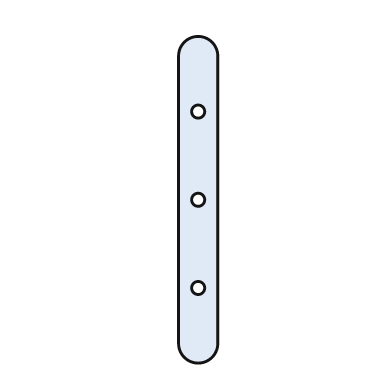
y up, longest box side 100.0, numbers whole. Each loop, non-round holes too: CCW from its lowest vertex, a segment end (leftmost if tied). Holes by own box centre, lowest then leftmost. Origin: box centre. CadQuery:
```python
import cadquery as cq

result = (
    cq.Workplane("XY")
    .moveTo(-6.0, -44.0)
    .threePointArc((0.0, -50.0), (6.0, -44.0))
    .lineTo(6.0, 44.0)
    .threePointArc((0.0, 50.0), (-6.0, 44.0))
    .close()
    .moveTo(0.0, -27.0)
    .circle(2.0)
    .moveTo(0.0, 0.0)
    .circle(2.0)
    .moveTo(0.0, 27.0)
    .circle(2.0)
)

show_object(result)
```